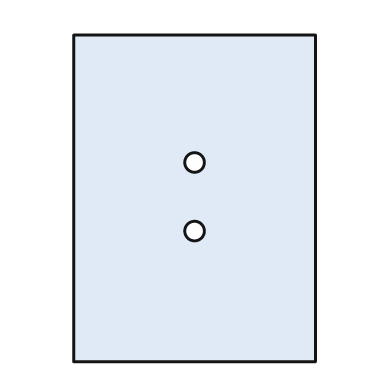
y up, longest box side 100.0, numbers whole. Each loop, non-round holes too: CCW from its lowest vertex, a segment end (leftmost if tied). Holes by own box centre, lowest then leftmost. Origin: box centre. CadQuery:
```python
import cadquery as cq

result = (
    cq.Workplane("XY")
    .moveTo(-37.0, -50.0)
    .lineTo(37.0, -50.0)
    .lineTo(37.0, 50.0)
    .lineTo(-37.0, 50.0)
    .close()
    .moveTo(0.0, -10.0)
    .circle(3.0)
    .moveTo(0.0, 11.0)
    .circle(3.0)
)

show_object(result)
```